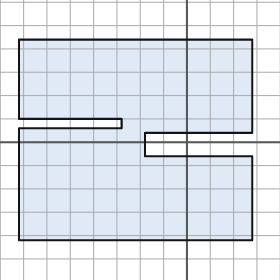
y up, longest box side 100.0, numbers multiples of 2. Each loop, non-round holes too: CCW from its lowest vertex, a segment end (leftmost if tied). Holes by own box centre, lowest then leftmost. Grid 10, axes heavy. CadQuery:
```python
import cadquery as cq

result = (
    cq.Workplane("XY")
    .moveTo(-72.0, -42.0)
    .lineTo(28.0, -42.0)
    .lineTo(28.0, -6.0)
    .lineTo(-18.0, -6.0)
    .lineTo(-18.0, 4.0)
    .lineTo(28.0, 4.0)
    .lineTo(28.0, 44.0)
    .lineTo(-72.0, 44.0)
    .lineTo(-72.0, 10.0)
    .lineTo(-28.0, 10.0)
    .lineTo(-28.0, 6.0)
    .lineTo(-72.0, 6.0)
    .close()
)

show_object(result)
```